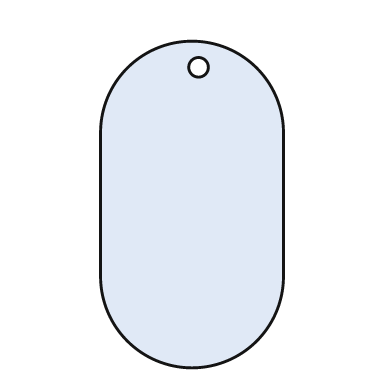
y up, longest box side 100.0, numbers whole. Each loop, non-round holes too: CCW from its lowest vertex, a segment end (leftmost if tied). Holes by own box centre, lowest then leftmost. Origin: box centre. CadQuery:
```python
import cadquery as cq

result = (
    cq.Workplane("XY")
    .moveTo(-28.0, -22.0)
    .threePointArc((0.0, -50.0), (28.0, -22.0))
    .lineTo(28.0, 22.0)
    .threePointArc((0.0, 50.0), (-28.0, 22.0))
    .close()
    .moveTo(2.0, 42.0)
    .circle(3.0)
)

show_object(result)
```